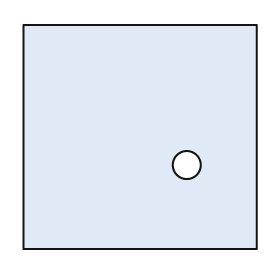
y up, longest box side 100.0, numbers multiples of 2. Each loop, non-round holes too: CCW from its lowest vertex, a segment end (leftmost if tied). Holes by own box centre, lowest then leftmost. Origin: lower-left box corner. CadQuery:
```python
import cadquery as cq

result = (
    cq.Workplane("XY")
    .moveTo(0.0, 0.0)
    .lineTo(100.0, 0.0)
    .lineTo(100.0, 96.0)
    .lineTo(0.0, 96.0)
    .close()
    .moveTo(70.0, 36.0)
    .circle(6.0)
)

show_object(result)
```